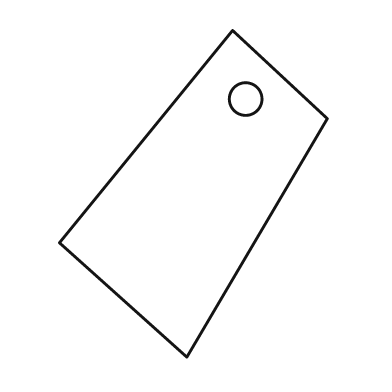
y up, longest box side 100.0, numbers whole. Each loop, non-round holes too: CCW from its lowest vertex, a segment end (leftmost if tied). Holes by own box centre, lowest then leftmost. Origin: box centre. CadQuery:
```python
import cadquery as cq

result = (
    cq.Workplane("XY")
    .moveTo(-2.0, -50.0)
    .lineTo(41.0, 23.0)
    .lineTo(12.0, 50.0)
    .lineTo(-41.0, -15.0)
    .close()
    .moveTo(16.0, 29.0)
    .circle(5.0)
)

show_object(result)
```